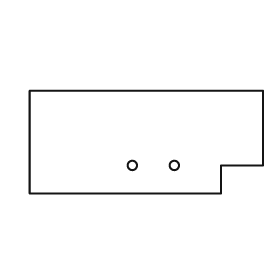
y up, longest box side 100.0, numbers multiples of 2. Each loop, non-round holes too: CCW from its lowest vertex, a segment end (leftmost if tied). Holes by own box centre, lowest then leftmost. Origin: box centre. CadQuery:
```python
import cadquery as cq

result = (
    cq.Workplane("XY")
    .moveTo(-50.0, -22.0)
    .lineTo(32.0, -22.0)
    .lineTo(32.0, -10.0)
    .lineTo(50.0, -10.0)
    .lineTo(50.0, 22.0)
    .lineTo(-50.0, 22.0)
    .close()
    .moveTo(-6.0, -10.0)
    .circle(2.0)
    .moveTo(12.0, -10.0)
    .circle(2.0)
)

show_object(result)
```